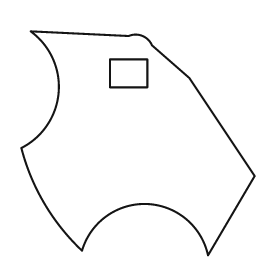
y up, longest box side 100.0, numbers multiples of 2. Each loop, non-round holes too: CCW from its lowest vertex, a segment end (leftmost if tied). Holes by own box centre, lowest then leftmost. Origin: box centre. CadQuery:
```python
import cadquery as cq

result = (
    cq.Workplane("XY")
    .moveTo(30.0, -48.0)
    .lineTo(50.0, -14.0)
    .lineTo(22.0, 28.0)
    .lineTo(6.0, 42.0)
    .threePointArc((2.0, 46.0), (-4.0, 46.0))
    .lineTo(-46.0, 48.0)
    .threePointArc((-34.0, 22.0), (-50.0, -2.0))
    .threePointArc((-40.0, -26.0), (-24.0, -46.0))
    .threePointArc((4.0, -26.0), (30.0, -48.0))
    .close()
    .moveTo(-12.0, 24.0)
    .lineTo(4.0, 24.0)
    .lineTo(4.0, 36.0)
    .lineTo(-12.0, 36.0)
    .close()
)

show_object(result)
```